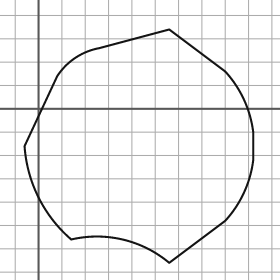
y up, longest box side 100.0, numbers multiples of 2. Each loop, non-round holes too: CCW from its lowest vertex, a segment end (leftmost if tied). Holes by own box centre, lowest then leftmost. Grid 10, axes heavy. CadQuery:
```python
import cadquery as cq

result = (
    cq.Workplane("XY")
    .moveTo(56.0, -66.0)
    .lineTo(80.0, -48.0)
    .threePointArc((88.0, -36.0), (92.0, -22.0))
    .lineTo(92.0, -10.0)
    .threePointArc((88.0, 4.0), (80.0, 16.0))
    .lineTo(56.0, 34.0)
    .lineTo(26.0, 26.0)
    .threePointArc((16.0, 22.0), (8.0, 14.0))
    .lineTo(-6.0, -16.0)
    .threePointArc((0.0, -38.0), (14.0, -56.0))
    .threePointArc((36.0, -56.0), (56.0, -66.0))
    .close()
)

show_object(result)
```